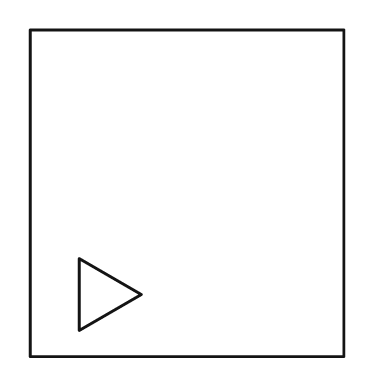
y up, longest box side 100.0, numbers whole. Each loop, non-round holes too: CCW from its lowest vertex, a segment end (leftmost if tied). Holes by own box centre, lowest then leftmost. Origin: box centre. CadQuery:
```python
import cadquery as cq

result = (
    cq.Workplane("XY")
    .moveTo(-48.0, -50.0)
    .lineTo(48.0, -50.0)
    .lineTo(48.0, 50.0)
    .lineTo(-48.0, 50.0)
    .close()
    .moveTo(-33.0, -42.0)
    .lineTo(-14.0, -31.0)
    .lineTo(-33.0, -20.0)
    .close()
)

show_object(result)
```